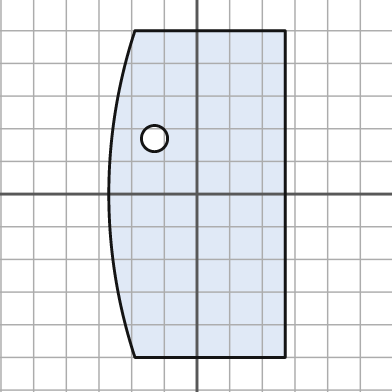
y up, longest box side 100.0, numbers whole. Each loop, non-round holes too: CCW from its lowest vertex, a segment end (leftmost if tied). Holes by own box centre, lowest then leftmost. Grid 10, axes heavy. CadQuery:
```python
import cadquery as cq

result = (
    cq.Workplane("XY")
    .moveTo(-19.0, -50.0)
    .lineTo(27.0, -50.0)
    .lineTo(27.0, 50.0)
    .lineTo(-19.0, 50.0)
    .threePointArc((-27.0, 0.0), (-19.0, -50.0))
    .close()
    .moveTo(-13.0, 17.0)
    .circle(4.0)
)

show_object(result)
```